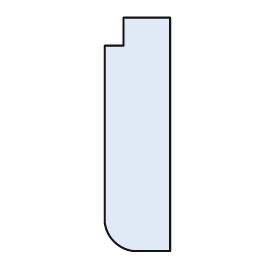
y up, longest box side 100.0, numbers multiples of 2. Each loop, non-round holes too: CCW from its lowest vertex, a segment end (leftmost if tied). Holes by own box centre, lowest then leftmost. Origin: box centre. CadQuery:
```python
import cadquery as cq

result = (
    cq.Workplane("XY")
    .moveTo(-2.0, -50.0)
    .lineTo(14.0, -50.0)
    .lineTo(14.0, 50.0)
    .lineTo(-6.0, 50.0)
    .lineTo(-6.0, 38.0)
    .lineTo(-14.0, 38.0)
    .lineTo(-14.0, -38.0)
    .threePointArc((-10.0, -46.0), (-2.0, -50.0))
    .close()
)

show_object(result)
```